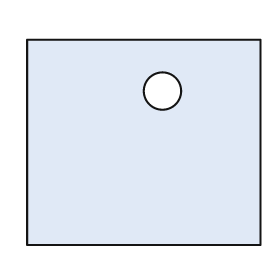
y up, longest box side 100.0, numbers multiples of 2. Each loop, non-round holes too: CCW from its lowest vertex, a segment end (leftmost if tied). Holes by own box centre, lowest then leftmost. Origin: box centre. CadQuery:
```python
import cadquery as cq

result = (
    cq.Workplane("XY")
    .moveTo(-50.0, -44.0)
    .lineTo(50.0, -44.0)
    .lineTo(50.0, 44.0)
    .lineTo(-50.0, 44.0)
    .close()
    .moveTo(8.0, 22.0)
    .circle(8.0)
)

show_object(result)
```